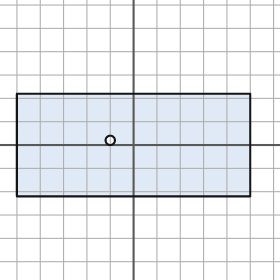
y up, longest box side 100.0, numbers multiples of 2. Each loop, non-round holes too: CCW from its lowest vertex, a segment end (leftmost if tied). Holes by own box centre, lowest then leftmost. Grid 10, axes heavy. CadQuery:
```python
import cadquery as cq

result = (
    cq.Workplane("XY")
    .moveTo(-50.0, -22.0)
    .lineTo(50.0, -22.0)
    .lineTo(50.0, 22.0)
    .lineTo(-50.0, 22.0)
    .close()
    .moveTo(-10.0, 2.0)
    .circle(2.0)
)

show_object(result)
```